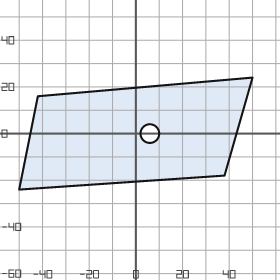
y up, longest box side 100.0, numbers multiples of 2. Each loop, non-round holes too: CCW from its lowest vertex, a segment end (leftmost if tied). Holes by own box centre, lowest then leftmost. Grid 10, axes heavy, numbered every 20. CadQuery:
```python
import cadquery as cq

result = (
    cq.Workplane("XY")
    .moveTo(-50.0, -24.0)
    .lineTo(38.0, -18.0)
    .lineTo(50.0, 24.0)
    .lineTo(-42.0, 16.0)
    .close()
    .moveTo(6.0, 0.0)
    .circle(4.0)
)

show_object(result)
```